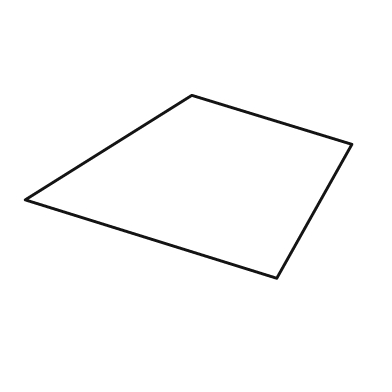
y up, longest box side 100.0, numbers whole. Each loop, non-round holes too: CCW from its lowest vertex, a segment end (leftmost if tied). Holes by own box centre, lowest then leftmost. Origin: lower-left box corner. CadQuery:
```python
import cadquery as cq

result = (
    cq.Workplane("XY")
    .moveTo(77.0, 0.0)
    .lineTo(100.0, 41.0)
    .lineTo(51.0, 56.0)
    .lineTo(0.0, 24.0)
    .close()
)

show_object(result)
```